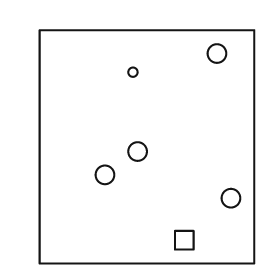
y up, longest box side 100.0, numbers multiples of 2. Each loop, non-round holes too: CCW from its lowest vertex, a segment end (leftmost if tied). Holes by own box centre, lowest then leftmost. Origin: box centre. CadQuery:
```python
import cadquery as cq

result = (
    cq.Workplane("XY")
    .moveTo(-46.0, -50.0)
    .lineTo(46.0, -50.0)
    .lineTo(46.0, 50.0)
    .lineTo(-46.0, 50.0)
    .close()
    .moveTo(12.0, -44.0)
    .lineTo(20.0, -44.0)
    .lineTo(20.0, -36.0)
    .lineTo(12.0, -36.0)
    .close()
    .moveTo(36.0, -22.0)
    .circle(4.0)
    .moveTo(-18.0, -12.0)
    .circle(4.0)
    .moveTo(-4.0, -2.0)
    .circle(4.0)
    .moveTo(-6.0, 32.0)
    .circle(2.0)
    .moveTo(30.0, 40.0)
    .circle(4.0)
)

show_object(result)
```